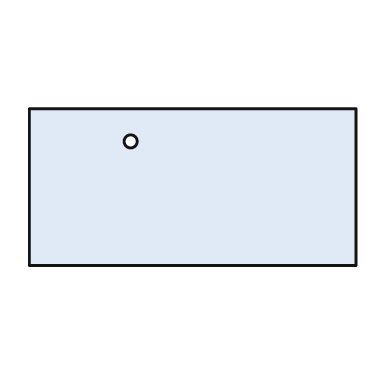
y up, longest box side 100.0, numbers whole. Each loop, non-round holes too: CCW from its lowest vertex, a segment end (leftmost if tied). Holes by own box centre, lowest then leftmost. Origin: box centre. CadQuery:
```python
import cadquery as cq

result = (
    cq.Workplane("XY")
    .moveTo(-50.0, -24.0)
    .lineTo(50.0, -24.0)
    .lineTo(50.0, 24.0)
    .lineTo(-50.0, 24.0)
    .close()
    .moveTo(-19.0, 14.0)
    .circle(2.0)
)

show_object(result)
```